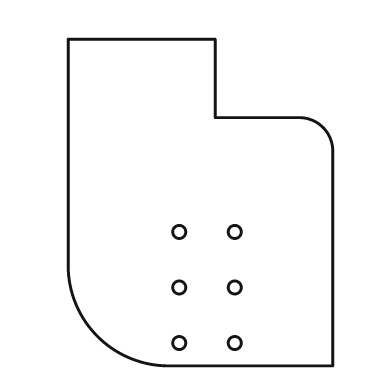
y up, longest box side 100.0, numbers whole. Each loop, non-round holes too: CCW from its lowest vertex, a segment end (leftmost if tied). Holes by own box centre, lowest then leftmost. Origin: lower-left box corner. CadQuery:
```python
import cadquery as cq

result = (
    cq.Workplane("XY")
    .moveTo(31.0, 0.0)
    .lineTo(81.0, 0.0)
    .lineTo(81.0, 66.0)
    .threePointArc((78.0, 73.0), (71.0, 76.0))
    .lineTo(45.0, 76.0)
    .lineTo(45.0, 100.0)
    .lineTo(0.0, 100.0)
    .lineTo(0.0, 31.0)
    .threePointArc((9.0, 9.0), (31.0, 0.0))
    .close()
    .moveTo(34.0, 7.0)
    .circle(2.0)
    .moveTo(51.0, 7.0)
    .circle(2.0)
    .moveTo(34.0, 24.0)
    .circle(2.0)
    .moveTo(51.0, 24.0)
    .circle(2.0)
    .moveTo(34.0, 41.0)
    .circle(2.0)
    .moveTo(51.0, 41.0)
    .circle(2.0)
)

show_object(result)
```